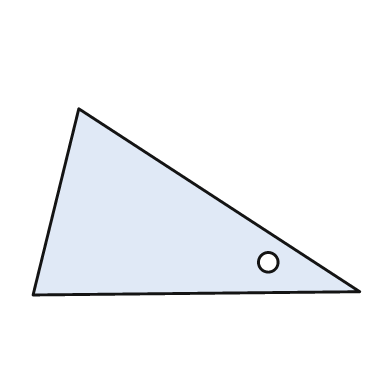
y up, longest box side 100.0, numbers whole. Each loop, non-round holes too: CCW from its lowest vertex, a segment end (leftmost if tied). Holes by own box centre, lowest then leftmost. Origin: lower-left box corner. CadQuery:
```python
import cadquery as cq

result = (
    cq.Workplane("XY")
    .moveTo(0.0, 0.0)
    .lineTo(100.0, 1.0)
    .lineTo(14.0, 57.0)
    .close()
    .moveTo(72.0, 10.0)
    .circle(3.0)
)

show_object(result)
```